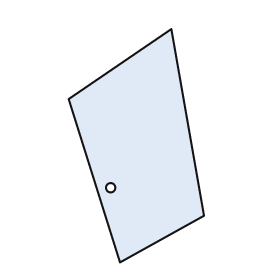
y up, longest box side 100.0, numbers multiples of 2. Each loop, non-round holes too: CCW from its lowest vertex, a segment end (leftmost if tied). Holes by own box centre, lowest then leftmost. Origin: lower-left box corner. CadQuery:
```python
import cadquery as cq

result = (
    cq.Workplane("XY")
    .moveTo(22.0, 0.0)
    .lineTo(58.0, 20.0)
    .lineTo(44.0, 100.0)
    .lineTo(0.0, 70.0)
    .close()
    .moveTo(18.0, 32.0)
    .circle(2.0)
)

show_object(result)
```